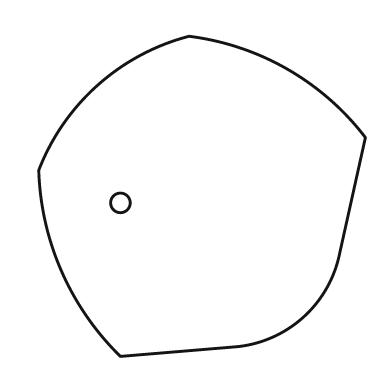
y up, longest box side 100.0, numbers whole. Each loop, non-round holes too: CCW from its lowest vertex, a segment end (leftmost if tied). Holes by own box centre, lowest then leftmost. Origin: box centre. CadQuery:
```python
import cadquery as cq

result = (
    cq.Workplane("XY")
    .moveTo(-25.0, -49.0)
    .lineTo(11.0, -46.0)
    .threePointArc((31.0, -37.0), (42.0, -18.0))
    .lineTo(50.0, 18.0)
    .threePointArc((26.0, 39.0), (-4.0, 49.0))
    .threePointArc((-32.0, 34.0), (-50.0, 8.0))
    .threePointArc((-43.0, -23.0), (-25.0, -49.0))
    .close()
    .moveTo(-25.0, -2.0)
    .circle(3.0)
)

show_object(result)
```